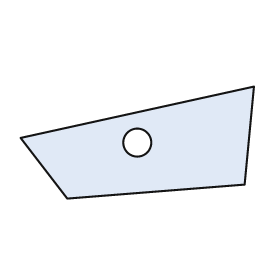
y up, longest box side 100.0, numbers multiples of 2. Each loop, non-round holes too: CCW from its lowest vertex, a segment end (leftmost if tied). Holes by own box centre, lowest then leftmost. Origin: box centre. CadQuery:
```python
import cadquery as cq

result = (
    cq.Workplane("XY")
    .moveTo(-30.0, -24.0)
    .lineTo(46.0, -18.0)
    .lineTo(50.0, 24.0)
    .lineTo(-50.0, 2.0)
    .close()
    .moveTo(0.0, 0.0)
    .circle(6.0)
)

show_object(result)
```